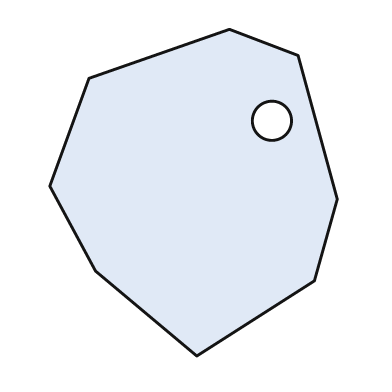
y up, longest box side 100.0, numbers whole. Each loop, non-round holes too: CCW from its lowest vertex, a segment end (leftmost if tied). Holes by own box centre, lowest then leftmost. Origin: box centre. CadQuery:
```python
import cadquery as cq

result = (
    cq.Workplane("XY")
    .moveTo(1.0, -50.0)
    .lineTo(37.0, -27.0)
    .lineTo(44.0, -2.0)
    .lineTo(32.0, 42.0)
    .lineTo(11.0, 50.0)
    .lineTo(-32.0, 35.0)
    .lineTo(-44.0, 2.0)
    .lineTo(-30.0, -24.0)
    .close()
    .moveTo(24.0, 22.0)
    .circle(6.0)
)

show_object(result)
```